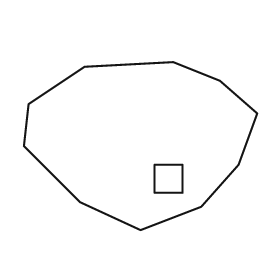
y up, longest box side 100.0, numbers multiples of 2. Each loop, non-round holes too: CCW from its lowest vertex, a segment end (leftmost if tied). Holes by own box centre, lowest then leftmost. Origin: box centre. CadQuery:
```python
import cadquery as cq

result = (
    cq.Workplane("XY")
    .moveTo(0.0, -36.0)
    .lineTo(26.0, -26.0)
    .lineTo(42.0, -8.0)
    .lineTo(50.0, 14.0)
    .lineTo(34.0, 28.0)
    .lineTo(14.0, 36.0)
    .lineTo(-24.0, 34.0)
    .lineTo(-48.0, 18.0)
    .lineTo(-50.0, 0.0)
    .lineTo(-26.0, -24.0)
    .close()
    .moveTo(6.0, -20.0)
    .lineTo(18.0, -20.0)
    .lineTo(18.0, -8.0)
    .lineTo(6.0, -8.0)
    .close()
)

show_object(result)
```